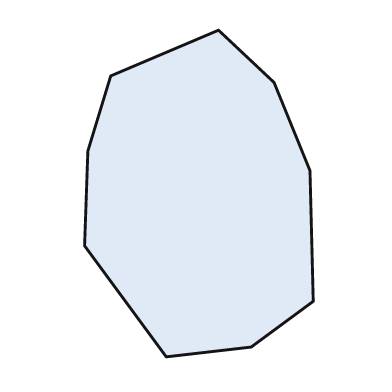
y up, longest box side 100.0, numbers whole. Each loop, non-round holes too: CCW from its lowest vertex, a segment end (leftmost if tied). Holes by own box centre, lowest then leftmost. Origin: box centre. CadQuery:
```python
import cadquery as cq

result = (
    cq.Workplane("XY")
    .moveTo(-10.0, -50.0)
    .lineTo(16.0, -47.0)
    .lineTo(35.0, -33.0)
    .lineTo(34.0, 7.0)
    .lineTo(23.0, 34.0)
    .lineTo(6.0, 50.0)
    .lineTo(-27.0, 36.0)
    .lineTo(-34.0, 13.0)
    .lineTo(-35.0, -16.0)
    .close()
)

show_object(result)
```